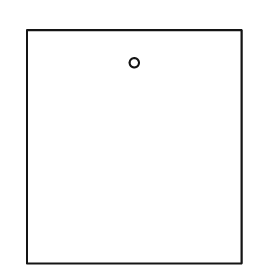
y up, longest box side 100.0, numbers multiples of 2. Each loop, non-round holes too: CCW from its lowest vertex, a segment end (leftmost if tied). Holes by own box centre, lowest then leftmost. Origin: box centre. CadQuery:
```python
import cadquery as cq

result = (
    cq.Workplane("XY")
    .moveTo(-46.0, -50.0)
    .lineTo(46.0, -50.0)
    .lineTo(46.0, 50.0)
    .lineTo(-46.0, 50.0)
    .close()
    .moveTo(0.0, 36.0)
    .circle(2.0)
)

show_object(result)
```